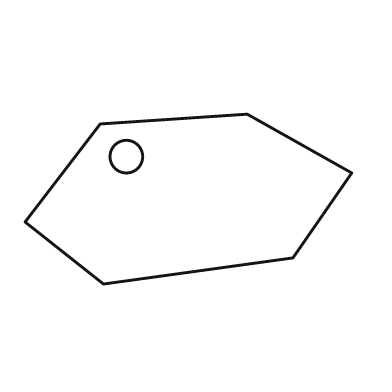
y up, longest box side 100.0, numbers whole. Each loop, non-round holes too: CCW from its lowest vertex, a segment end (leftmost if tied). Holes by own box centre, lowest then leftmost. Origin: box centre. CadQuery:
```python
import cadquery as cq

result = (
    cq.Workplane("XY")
    .moveTo(-26.0, -26.0)
    .lineTo(32.0, -18.0)
    .lineTo(50.0, 8.0)
    .lineTo(18.0, 26.0)
    .lineTo(-27.0, 23.0)
    .lineTo(-50.0, -7.0)
    .close()
    .moveTo(-19.0, 13.0)
    .circle(5.0)
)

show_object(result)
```